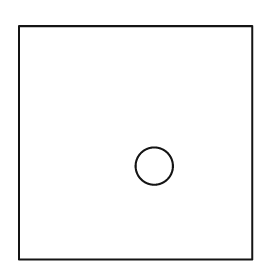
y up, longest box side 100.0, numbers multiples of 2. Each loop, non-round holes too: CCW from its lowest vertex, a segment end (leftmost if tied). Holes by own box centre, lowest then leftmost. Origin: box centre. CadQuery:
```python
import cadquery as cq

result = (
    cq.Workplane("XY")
    .moveTo(-50.0, -50.0)
    .lineTo(50.0, -50.0)
    .lineTo(50.0, 50.0)
    .lineTo(-50.0, 50.0)
    .close()
    .moveTo(8.0, -10.0)
    .circle(8.0)
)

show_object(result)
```